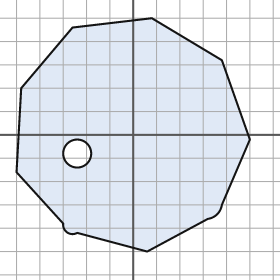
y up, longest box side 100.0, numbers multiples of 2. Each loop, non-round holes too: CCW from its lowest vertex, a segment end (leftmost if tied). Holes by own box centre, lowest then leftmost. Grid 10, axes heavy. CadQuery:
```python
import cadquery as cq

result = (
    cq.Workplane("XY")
    .moveTo(6.0, -50.0)
    .lineTo(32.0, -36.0)
    .threePointArc((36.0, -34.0), (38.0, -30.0))
    .lineTo(50.0, -2.0)
    .lineTo(38.0, 32.0)
    .lineTo(8.0, 50.0)
    .lineTo(-26.0, 46.0)
    .lineTo(-48.0, 20.0)
    .lineTo(-50.0, -16.0)
    .lineTo(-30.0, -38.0)
    .threePointArc((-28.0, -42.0), (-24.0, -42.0))
    .close()
    .moveTo(-24.0, -8.0)
    .circle(6.0)
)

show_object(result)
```